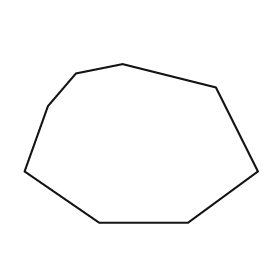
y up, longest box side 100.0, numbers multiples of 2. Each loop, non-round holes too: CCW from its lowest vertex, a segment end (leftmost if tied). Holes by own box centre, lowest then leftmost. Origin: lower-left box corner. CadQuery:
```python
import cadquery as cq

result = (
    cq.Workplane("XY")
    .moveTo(32.0, 0.0)
    .lineTo(70.0, 0.0)
    .lineTo(100.0, 22.0)
    .lineTo(82.0, 58.0)
    .lineTo(42.0, 68.0)
    .lineTo(22.0, 64.0)
    .lineTo(10.0, 50.0)
    .lineTo(0.0, 22.0)
    .close()
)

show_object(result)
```